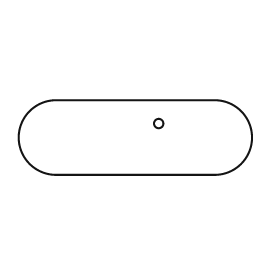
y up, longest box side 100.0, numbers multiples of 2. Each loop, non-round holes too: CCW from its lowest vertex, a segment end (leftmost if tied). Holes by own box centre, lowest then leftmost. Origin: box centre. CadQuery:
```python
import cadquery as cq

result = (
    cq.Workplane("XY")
    .moveTo(-34.0, -16.0)
    .lineTo(34.0, -16.0)
    .threePointArc((50.0, 0.0), (34.0, 16.0))
    .lineTo(-34.0, 16.0)
    .threePointArc((-50.0, 0.0), (-34.0, -16.0))
    .close()
    .moveTo(10.0, 6.0)
    .circle(2.0)
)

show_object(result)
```